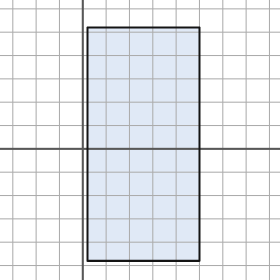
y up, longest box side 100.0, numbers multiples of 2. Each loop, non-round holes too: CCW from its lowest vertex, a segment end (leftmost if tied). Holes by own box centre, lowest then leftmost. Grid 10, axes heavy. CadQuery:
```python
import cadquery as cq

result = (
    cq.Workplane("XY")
    .moveTo(2.0, -48.0)
    .lineTo(50.0, -48.0)
    .lineTo(50.0, 52.0)
    .lineTo(2.0, 52.0)
    .close()
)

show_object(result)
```